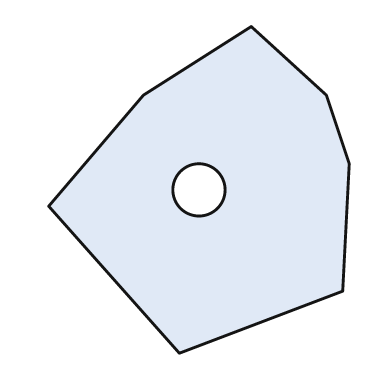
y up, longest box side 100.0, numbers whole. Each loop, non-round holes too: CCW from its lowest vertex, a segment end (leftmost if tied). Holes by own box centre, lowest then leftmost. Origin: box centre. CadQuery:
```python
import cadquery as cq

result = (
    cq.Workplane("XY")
    .moveTo(-6.0, -50.0)
    .lineTo(44.0, -31.0)
    .lineTo(46.0, 8.0)
    .lineTo(39.0, 29.0)
    .lineTo(16.0, 50.0)
    .lineTo(-17.0, 29.0)
    .lineTo(-46.0, -5.0)
    .close()
    .moveTo(0.0, 0.0)
    .circle(8.0)
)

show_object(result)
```